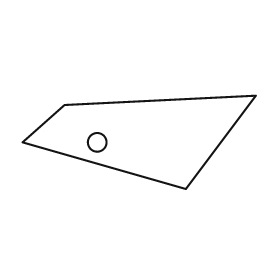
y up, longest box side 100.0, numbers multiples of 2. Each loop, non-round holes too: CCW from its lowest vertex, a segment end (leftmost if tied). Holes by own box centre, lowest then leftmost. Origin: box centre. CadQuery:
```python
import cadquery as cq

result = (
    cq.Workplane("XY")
    .moveTo(20.0, -20.0)
    .lineTo(50.0, 20.0)
    .lineTo(-32.0, 16.0)
    .lineTo(-50.0, 0.0)
    .close()
    .moveTo(-18.0, 0.0)
    .circle(4.0)
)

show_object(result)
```